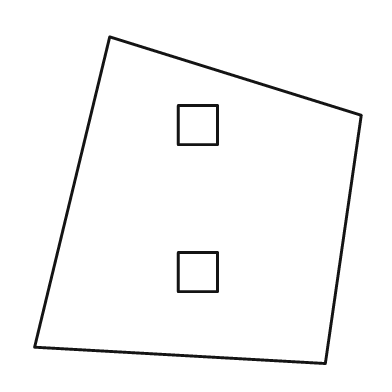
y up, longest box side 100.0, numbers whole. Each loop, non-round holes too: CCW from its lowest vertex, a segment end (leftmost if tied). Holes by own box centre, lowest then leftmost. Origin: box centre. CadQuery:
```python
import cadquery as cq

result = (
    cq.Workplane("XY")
    .moveTo(39.0, -50.0)
    .lineTo(50.0, 26.0)
    .lineTo(-27.0, 50.0)
    .lineTo(-50.0, -45.0)
    .close()
    .moveTo(-6.0, -28.0)
    .lineTo(6.0, -28.0)
    .lineTo(6.0, -16.0)
    .lineTo(-6.0, -16.0)
    .close()
    .moveTo(-6.0, 17.0)
    .lineTo(6.0, 17.0)
    .lineTo(6.0, 29.0)
    .lineTo(-6.0, 29.0)
    .close()
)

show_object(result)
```